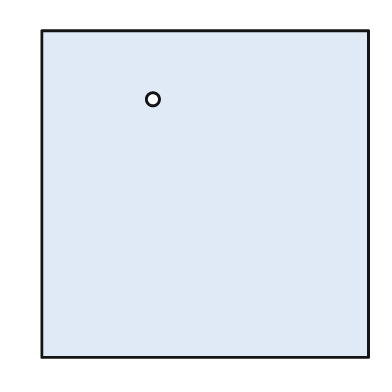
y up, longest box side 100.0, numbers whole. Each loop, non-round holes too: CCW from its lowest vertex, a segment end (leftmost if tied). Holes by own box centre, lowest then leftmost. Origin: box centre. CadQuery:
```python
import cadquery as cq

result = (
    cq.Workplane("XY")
    .moveTo(-50.0, -50.0)
    .lineTo(50.0, -50.0)
    .lineTo(50.0, 50.0)
    .lineTo(-50.0, 50.0)
    .close()
    .moveTo(-16.0, 29.0)
    .circle(2.0)
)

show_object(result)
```